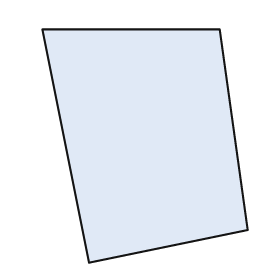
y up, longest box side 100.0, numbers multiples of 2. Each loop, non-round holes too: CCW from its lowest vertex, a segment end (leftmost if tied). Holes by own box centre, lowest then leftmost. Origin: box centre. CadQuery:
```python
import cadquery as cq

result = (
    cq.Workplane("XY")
    .moveTo(-24.0, -50.0)
    .lineTo(44.0, -36.0)
    .lineTo(32.0, 50.0)
    .lineTo(-44.0, 50.0)
    .close()
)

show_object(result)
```